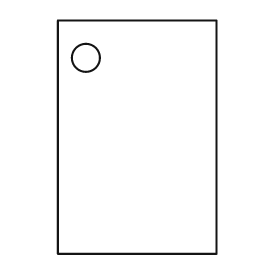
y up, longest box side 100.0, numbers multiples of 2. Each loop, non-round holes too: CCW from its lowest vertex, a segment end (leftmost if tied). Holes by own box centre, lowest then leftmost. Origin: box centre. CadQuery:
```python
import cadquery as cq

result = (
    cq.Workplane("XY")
    .moveTo(-34.0, -50.0)
    .lineTo(34.0, -50.0)
    .lineTo(34.0, 50.0)
    .lineTo(-34.0, 50.0)
    .close()
    .moveTo(-22.0, 34.0)
    .circle(6.0)
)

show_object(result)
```